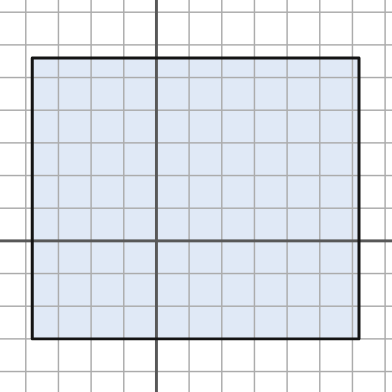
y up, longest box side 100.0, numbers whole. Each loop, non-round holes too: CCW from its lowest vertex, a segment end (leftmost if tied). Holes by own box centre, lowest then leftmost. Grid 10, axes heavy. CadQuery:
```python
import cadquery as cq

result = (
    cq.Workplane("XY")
    .moveTo(-38.0, -30.0)
    .lineTo(62.0, -30.0)
    .lineTo(62.0, 56.0)
    .lineTo(-38.0, 56.0)
    .close()
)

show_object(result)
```